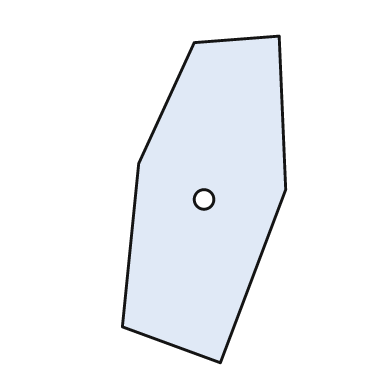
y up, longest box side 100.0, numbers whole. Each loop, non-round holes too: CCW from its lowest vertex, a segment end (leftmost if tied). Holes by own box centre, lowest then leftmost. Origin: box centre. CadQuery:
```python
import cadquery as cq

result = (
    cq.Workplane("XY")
    .moveTo(5.0, -50.0)
    .lineTo(25.0, 3.0)
    .lineTo(23.0, 50.0)
    .lineTo(-3.0, 48.0)
    .lineTo(-20.0, 11.0)
    .lineTo(-25.0, -39.0)
    .close()
    .moveTo(0.0, 0.0)
    .circle(3.0)
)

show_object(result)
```